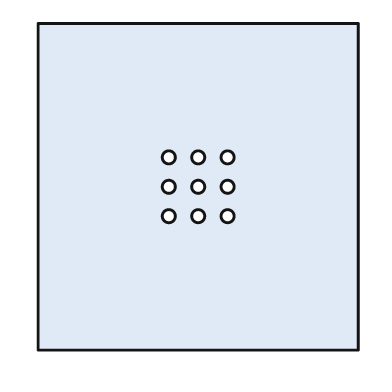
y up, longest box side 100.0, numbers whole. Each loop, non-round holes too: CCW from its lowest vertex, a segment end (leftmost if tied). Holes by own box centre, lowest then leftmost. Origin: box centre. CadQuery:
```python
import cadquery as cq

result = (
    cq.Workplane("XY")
    .moveTo(-49.0, -50.0)
    .lineTo(49.0, -50.0)
    .lineTo(49.0, 50.0)
    .lineTo(-49.0, 50.0)
    .close()
    .moveTo(-9.0, -9.0)
    .circle(2.0)
    .moveTo(0.0, -9.0)
    .circle(2.0)
    .moveTo(9.0, -9.0)
    .circle(2.0)
    .moveTo(-9.0, 0.0)
    .circle(2.0)
    .moveTo(0.0, 0.0)
    .circle(2.0)
    .moveTo(9.0, 0.0)
    .circle(2.0)
    .moveTo(-9.0, 9.0)
    .circle(2.0)
    .moveTo(0.0, 9.0)
    .circle(2.0)
    .moveTo(9.0, 9.0)
    .circle(2.0)
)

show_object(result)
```